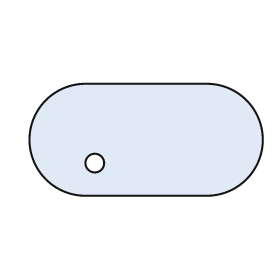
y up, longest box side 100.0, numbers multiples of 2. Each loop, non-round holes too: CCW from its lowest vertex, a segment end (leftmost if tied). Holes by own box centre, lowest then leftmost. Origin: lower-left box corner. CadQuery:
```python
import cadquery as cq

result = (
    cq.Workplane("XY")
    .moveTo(24.0, 0.0)
    .lineTo(76.0, 0.0)
    .threePointArc((100.0, 24.0), (76.0, 48.0))
    .lineTo(24.0, 48.0)
    .threePointArc((0.0, 24.0), (24.0, 0.0))
    .close()
    .moveTo(28.0, 14.0)
    .circle(4.0)
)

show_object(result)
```